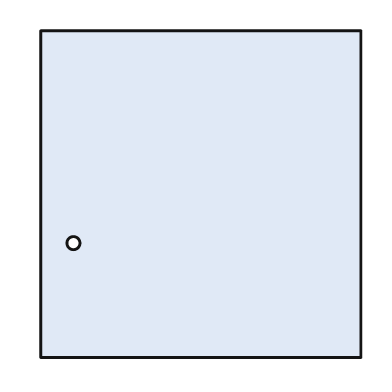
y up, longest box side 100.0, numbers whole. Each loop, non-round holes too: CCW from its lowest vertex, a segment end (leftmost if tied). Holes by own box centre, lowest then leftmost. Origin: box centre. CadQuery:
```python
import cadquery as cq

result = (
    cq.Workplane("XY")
    .moveTo(-49.0, -50.0)
    .lineTo(49.0, -50.0)
    .lineTo(49.0, 50.0)
    .lineTo(-49.0, 50.0)
    .close()
    .moveTo(-39.0, -15.0)
    .circle(2.0)
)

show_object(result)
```